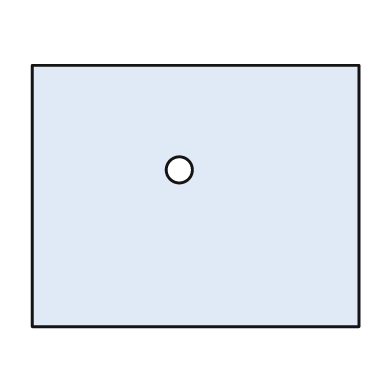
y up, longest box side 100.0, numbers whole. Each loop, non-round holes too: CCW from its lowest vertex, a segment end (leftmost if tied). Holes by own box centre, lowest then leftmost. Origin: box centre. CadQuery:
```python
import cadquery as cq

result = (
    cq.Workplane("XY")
    .moveTo(-50.0, -40.0)
    .lineTo(50.0, -40.0)
    .lineTo(50.0, 40.0)
    .lineTo(-50.0, 40.0)
    .close()
    .moveTo(-5.0, 8.0)
    .circle(4.0)
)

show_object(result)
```